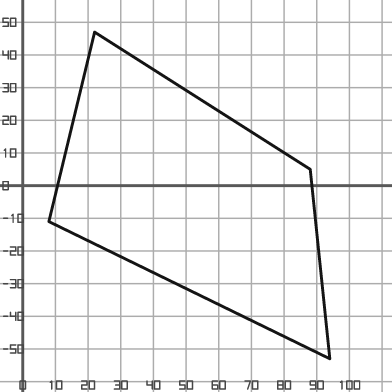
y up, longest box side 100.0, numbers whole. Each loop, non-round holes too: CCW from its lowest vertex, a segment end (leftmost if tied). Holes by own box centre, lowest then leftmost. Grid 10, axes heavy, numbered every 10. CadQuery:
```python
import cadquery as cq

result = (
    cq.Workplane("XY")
    .moveTo(94.0, -53.0)
    .lineTo(88.0, 5.0)
    .lineTo(22.0, 47.0)
    .lineTo(8.0, -11.0)
    .close()
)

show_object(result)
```